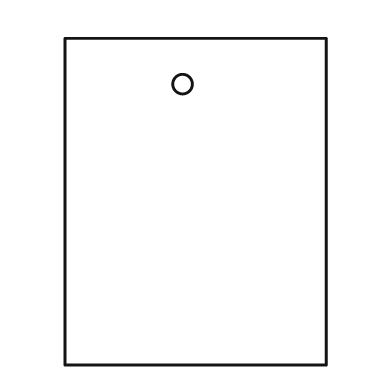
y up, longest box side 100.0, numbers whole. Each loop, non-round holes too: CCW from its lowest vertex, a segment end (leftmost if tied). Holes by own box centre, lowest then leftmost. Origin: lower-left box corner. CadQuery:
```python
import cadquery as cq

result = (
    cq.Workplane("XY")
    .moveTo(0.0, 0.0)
    .lineTo(80.0, 0.0)
    .lineTo(80.0, 100.0)
    .lineTo(0.0, 100.0)
    .close()
    .moveTo(36.0, 86.0)
    .circle(3.0)
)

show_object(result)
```